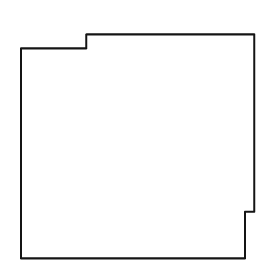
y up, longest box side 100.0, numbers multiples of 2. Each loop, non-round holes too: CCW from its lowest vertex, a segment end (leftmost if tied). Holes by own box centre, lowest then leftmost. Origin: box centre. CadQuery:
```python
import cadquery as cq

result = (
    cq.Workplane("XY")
    .moveTo(-50.0, -48.0)
    .lineTo(46.0, -48.0)
    .lineTo(46.0, -28.0)
    .lineTo(50.0, -28.0)
    .lineTo(50.0, 48.0)
    .lineTo(-22.0, 48.0)
    .lineTo(-22.0, 42.0)
    .lineTo(-50.0, 42.0)
    .close()
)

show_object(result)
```